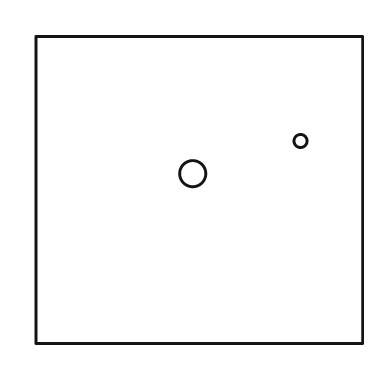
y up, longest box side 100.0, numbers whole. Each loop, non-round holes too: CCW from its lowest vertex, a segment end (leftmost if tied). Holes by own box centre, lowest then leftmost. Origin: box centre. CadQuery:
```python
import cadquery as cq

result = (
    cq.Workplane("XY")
    .moveTo(-50.0, -47.0)
    .lineTo(50.0, -47.0)
    .lineTo(50.0, 47.0)
    .lineTo(-50.0, 47.0)
    .close()
    .moveTo(-2.0, 5.0)
    .circle(4.0)
    .moveTo(31.0, 15.0)
    .circle(2.0)
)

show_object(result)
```